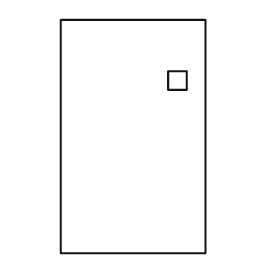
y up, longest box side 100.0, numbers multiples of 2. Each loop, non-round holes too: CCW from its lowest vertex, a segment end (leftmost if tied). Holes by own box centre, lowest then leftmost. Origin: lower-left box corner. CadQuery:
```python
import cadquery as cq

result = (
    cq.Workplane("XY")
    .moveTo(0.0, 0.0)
    .lineTo(62.0, 0.0)
    .lineTo(62.0, 100.0)
    .lineTo(0.0, 100.0)
    .close()
    .moveTo(46.0, 70.0)
    .lineTo(54.0, 70.0)
    .lineTo(54.0, 78.0)
    .lineTo(46.0, 78.0)
    .close()
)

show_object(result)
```